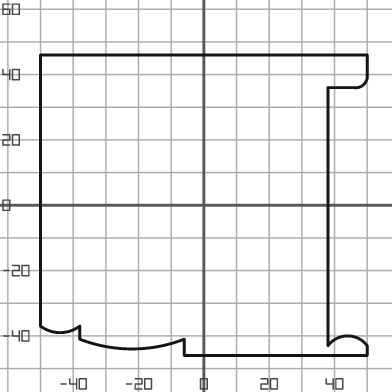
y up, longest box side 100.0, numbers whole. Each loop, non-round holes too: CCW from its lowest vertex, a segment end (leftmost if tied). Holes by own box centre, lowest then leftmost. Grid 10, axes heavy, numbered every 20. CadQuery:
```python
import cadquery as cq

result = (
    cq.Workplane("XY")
    .moveTo(-6.0, -46.0)
    .lineTo(50.0, -46.0)
    .lineTo(50.0, -43.0)
    .threePointArc((44.0, -40.0), (38.0, -43.0))
    .lineTo(38.0, 36.0)
    .lineTo(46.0, 36.0)
    .threePointArc((49.0, 37.0), (50.0, 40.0))
    .lineTo(50.0, 46.0)
    .lineTo(-50.0, 46.0)
    .lineTo(-50.0, -37.0)
    .threePointArc((-44.0, -39.0), (-38.0, -37.0))
    .lineTo(-38.0, -41.0)
    .threePointArc((-22.0, -44.0), (-6.0, -41.0))
    .close()
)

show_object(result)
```